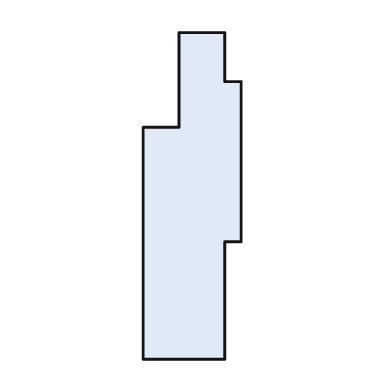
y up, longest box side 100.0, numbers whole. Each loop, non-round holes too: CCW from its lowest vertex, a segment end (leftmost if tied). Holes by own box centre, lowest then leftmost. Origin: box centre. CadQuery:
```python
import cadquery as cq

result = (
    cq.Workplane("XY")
    .moveTo(-15.0, -50.0)
    .lineTo(10.0, -50.0)
    .lineTo(10.0, -14.0)
    .lineTo(15.0, -14.0)
    .lineTo(15.0, 35.0)
    .lineTo(10.0, 35.0)
    .lineTo(10.0, 50.0)
    .lineTo(-4.0, 50.0)
    .lineTo(-4.0, 21.0)
    .lineTo(-15.0, 21.0)
    .close()
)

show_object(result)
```